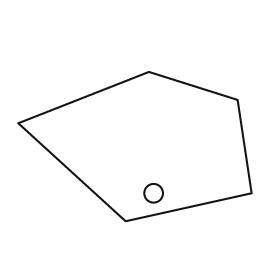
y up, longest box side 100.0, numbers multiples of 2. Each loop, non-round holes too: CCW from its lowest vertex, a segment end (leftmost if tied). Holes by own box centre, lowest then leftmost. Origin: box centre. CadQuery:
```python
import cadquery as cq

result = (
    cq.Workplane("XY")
    .moveTo(-4.0, -32.0)
    .lineTo(50.0, -20.0)
    .lineTo(44.0, 20.0)
    .lineTo(6.0, 32.0)
    .lineTo(-50.0, 10.0)
    .close()
    .moveTo(8.0, -20.0)
    .circle(4.0)
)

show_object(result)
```